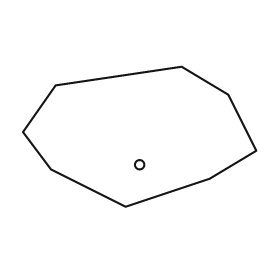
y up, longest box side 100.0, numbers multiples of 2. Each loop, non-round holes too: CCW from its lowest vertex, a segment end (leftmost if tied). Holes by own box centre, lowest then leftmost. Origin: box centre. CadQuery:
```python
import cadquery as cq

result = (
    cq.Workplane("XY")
    .moveTo(-6.0, -30.0)
    .lineTo(30.0, -18.0)
    .lineTo(50.0, -6.0)
    .lineTo(38.0, 18.0)
    .lineTo(18.0, 30.0)
    .lineTo(-36.0, 22.0)
    .lineTo(-50.0, 2.0)
    .lineTo(-38.0, -14.0)
    .close()
    .moveTo(0.0, -12.0)
    .circle(2.0)
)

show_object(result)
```